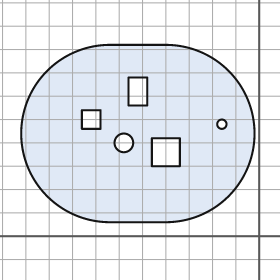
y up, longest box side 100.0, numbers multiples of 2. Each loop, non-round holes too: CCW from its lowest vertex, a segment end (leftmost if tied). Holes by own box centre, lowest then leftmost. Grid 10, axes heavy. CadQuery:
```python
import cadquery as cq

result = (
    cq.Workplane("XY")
    .moveTo(-64.0, 6.0)
    .lineTo(-40.0, 6.0)
    .threePointArc((-2.0, 44.0), (-40.0, 82.0))
    .lineTo(-64.0, 82.0)
    .threePointArc((-102.0, 44.0), (-64.0, 6.0))
    .close()
    .moveTo(-46.0, 30.0)
    .lineTo(-34.0, 30.0)
    .lineTo(-34.0, 42.0)
    .lineTo(-46.0, 42.0)
    .close()
    .moveTo(-58.0, 40.0)
    .circle(4.0)
    .moveTo(-16.0, 48.0)
    .circle(2.0)
    .moveTo(-76.0, 46.0)
    .lineTo(-68.0, 46.0)
    .lineTo(-68.0, 54.0)
    .lineTo(-76.0, 54.0)
    .close()
    .moveTo(-56.0, 56.0)
    .lineTo(-48.0, 56.0)
    .lineTo(-48.0, 68.0)
    .lineTo(-56.0, 68.0)
    .close()
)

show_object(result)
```